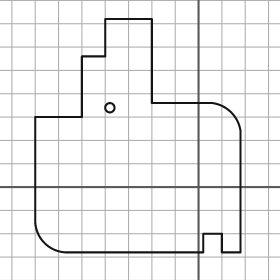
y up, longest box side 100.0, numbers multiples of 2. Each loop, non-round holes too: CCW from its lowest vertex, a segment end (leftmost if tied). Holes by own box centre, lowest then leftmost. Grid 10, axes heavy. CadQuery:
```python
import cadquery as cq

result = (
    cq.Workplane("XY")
    .moveTo(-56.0, -28.0)
    .lineTo(2.0, -28.0)
    .lineTo(2.0, -20.0)
    .lineTo(10.0, -20.0)
    .lineTo(10.0, -28.0)
    .lineTo(18.0, -28.0)
    .lineTo(18.0, 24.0)
    .threePointArc((14.0, 32.0), (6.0, 36.0))
    .lineTo(-20.0, 36.0)
    .lineTo(-20.0, 72.0)
    .lineTo(-40.0, 72.0)
    .lineTo(-40.0, 56.0)
    .lineTo(-50.0, 56.0)
    .lineTo(-50.0, 30.0)
    .lineTo(-70.0, 30.0)
    .lineTo(-70.0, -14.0)
    .threePointArc((-66.0, -24.0), (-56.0, -28.0))
    .close()
    .moveTo(-38.0, 34.0)
    .circle(2.0)
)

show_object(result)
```